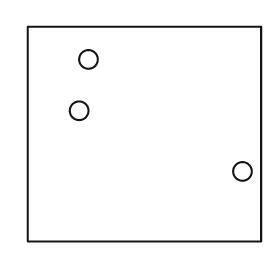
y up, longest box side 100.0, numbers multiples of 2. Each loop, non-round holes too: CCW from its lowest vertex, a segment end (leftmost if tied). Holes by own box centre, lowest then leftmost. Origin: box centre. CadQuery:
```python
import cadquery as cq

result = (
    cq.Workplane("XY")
    .moveTo(-50.0, -46.0)
    .lineTo(50.0, -46.0)
    .lineTo(50.0, 46.0)
    .lineTo(-50.0, 46.0)
    .close()
    .moveTo(42.0, -16.0)
    .circle(4.0)
    .moveTo(-28.0, 10.0)
    .circle(4.0)
    .moveTo(-24.0, 32.0)
    .circle(4.0)
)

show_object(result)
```